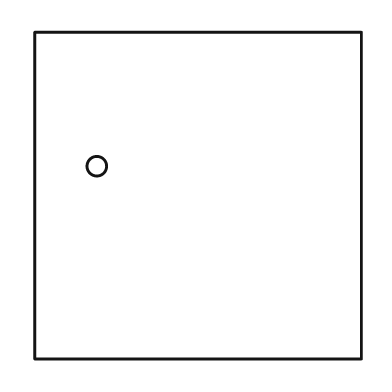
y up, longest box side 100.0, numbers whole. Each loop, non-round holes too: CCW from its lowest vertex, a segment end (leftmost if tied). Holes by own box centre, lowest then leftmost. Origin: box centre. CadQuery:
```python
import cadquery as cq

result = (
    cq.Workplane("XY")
    .moveTo(-50.0, -50.0)
    .lineTo(50.0, -50.0)
    .lineTo(50.0, 50.0)
    .lineTo(-50.0, 50.0)
    .close()
    .moveTo(-31.0, 9.0)
    .circle(3.0)
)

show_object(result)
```